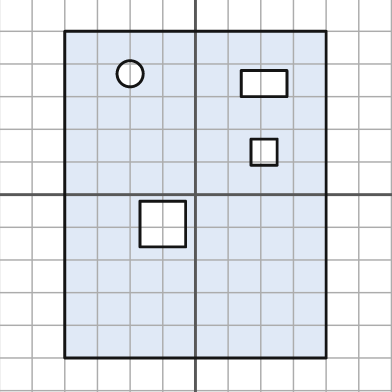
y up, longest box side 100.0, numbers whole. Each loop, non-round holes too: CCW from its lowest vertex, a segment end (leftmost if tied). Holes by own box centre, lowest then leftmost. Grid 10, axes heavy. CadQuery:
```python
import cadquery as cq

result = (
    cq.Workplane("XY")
    .moveTo(-40.0, -50.0)
    .lineTo(40.0, -50.0)
    .lineTo(40.0, 50.0)
    .lineTo(-40.0, 50.0)
    .close()
    .moveTo(-17.0, -16.0)
    .lineTo(-3.0, -16.0)
    .lineTo(-3.0, -2.0)
    .lineTo(-17.0, -2.0)
    .close()
    .moveTo(17.0, 9.0)
    .lineTo(25.0, 9.0)
    .lineTo(25.0, 17.0)
    .lineTo(17.0, 17.0)
    .close()
    .moveTo(14.0, 30.0)
    .lineTo(28.0, 30.0)
    .lineTo(28.0, 38.0)
    .lineTo(14.0, 38.0)
    .close()
    .moveTo(-20.0, 37.0)
    .circle(4.0)
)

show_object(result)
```